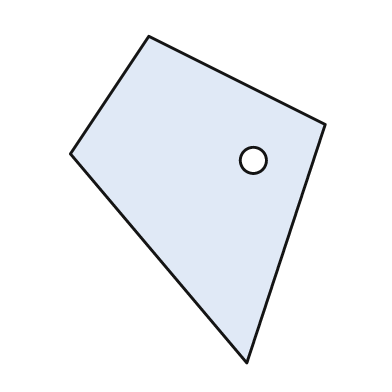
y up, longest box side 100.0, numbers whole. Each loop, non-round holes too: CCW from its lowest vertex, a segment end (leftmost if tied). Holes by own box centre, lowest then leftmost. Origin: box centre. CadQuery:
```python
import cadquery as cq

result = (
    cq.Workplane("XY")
    .moveTo(15.0, -50.0)
    .lineTo(39.0, 23.0)
    .lineTo(-15.0, 50.0)
    .lineTo(-39.0, 14.0)
    .close()
    .moveTo(17.0, 12.0)
    .circle(4.0)
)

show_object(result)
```